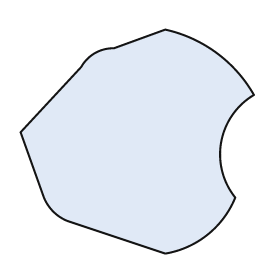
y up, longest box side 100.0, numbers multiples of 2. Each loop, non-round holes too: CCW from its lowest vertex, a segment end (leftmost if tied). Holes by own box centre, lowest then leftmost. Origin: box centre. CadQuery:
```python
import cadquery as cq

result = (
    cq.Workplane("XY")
    .moveTo(12.0, -48.0)
    .threePointArc((30.0, -40.0), (42.0, -24.0))
    .threePointArc((36.0, 0.0), (50.0, 20.0))
    .threePointArc((34.0, 38.0), (12.0, 48.0))
    .lineTo(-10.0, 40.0)
    .threePointArc((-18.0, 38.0), (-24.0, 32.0))
    .lineTo(-50.0, 4.0)
    .lineTo(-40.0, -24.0)
    .threePointArc((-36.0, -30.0), (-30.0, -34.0))
    .close()
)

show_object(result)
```